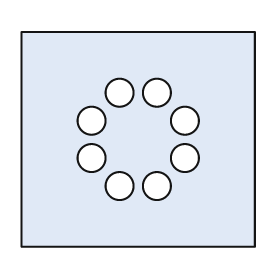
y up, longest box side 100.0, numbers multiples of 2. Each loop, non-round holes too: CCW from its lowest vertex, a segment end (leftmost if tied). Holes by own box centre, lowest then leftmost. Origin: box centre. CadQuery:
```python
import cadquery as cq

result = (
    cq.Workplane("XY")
    .moveTo(-50.0, -46.0)
    .lineTo(50.0, -46.0)
    .lineTo(50.0, 46.0)
    .lineTo(-50.0, 46.0)
    .close()
    .moveTo(-8.0, -20.0)
    .circle(6.0)
    .moveTo(8.0, -20.0)
    .circle(6.0)
    .moveTo(-20.0, -8.0)
    .circle(6.0)
    .moveTo(20.0, -8.0)
    .circle(6.0)
    .moveTo(-20.0, 8.0)
    .circle(6.0)
    .moveTo(20.0, 8.0)
    .circle(6.0)
    .moveTo(-8.0, 20.0)
    .circle(6.0)
    .moveTo(8.0, 20.0)
    .circle(6.0)
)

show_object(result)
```